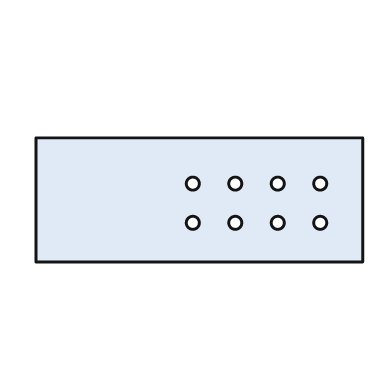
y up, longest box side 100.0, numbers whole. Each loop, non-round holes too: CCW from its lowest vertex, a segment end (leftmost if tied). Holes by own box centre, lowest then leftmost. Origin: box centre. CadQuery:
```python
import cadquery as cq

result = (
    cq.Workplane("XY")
    .moveTo(-50.0, -19.0)
    .lineTo(50.0, -19.0)
    .lineTo(50.0, 19.0)
    .lineTo(-50.0, 19.0)
    .close()
    .moveTo(-2.0, -7.0)
    .circle(2.0)
    .moveTo(11.0, -7.0)
    .circle(2.0)
    .moveTo(24.0, -7.0)
    .circle(2.0)
    .moveTo(37.0, -7.0)
    .circle(2.0)
    .moveTo(-2.0, 5.0)
    .circle(2.0)
    .moveTo(11.0, 5.0)
    .circle(2.0)
    .moveTo(24.0, 5.0)
    .circle(2.0)
    .moveTo(37.0, 5.0)
    .circle(2.0)
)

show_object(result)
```